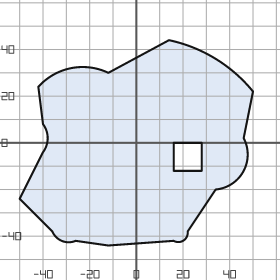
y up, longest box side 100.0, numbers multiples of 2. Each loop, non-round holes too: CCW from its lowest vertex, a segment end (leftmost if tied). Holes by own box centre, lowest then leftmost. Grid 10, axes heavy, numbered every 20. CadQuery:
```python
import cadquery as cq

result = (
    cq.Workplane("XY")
    .moveTo(-12.0, -44.0)
    .lineTo(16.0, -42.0)
    .threePointArc((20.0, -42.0), (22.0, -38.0))
    .lineTo(34.0, -20.0)
    .threePointArc((46.0, -12.0), (46.0, 2.0))
    .lineTo(50.0, 22.0)
    .threePointArc((34.0, 36.0), (14.0, 44.0))
    .lineTo(-12.0, 30.0)
    .threePointArc((-28.0, 32.0), (-42.0, 24.0))
    .lineTo(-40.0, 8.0)
    .threePointArc((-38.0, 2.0), (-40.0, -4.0))
    .lineTo(-50.0, -24.0)
    .lineTo(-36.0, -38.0)
    .threePointArc((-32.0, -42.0), (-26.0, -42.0))
    .close()
    .moveTo(16.0, -12.0)
    .lineTo(28.0, -12.0)
    .lineTo(28.0, 0.0)
    .lineTo(16.0, 0.0)
    .close()
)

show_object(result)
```